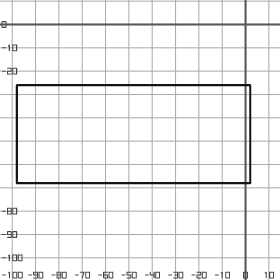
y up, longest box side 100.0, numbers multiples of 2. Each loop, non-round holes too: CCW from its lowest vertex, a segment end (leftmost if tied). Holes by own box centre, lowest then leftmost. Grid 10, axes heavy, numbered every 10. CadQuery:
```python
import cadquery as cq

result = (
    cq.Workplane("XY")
    .moveTo(-98.0, -68.0)
    .lineTo(2.0, -68.0)
    .lineTo(2.0, -26.0)
    .lineTo(-98.0, -26.0)
    .close()
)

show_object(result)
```